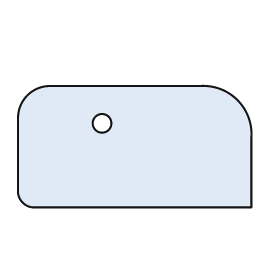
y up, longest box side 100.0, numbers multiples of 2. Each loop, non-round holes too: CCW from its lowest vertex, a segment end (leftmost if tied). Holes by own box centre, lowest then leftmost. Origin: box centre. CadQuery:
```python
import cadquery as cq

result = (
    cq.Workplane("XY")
    .moveTo(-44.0, -26.0)
    .lineTo(50.0, -26.0)
    .lineTo(50.0, 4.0)
    .threePointArc((44.0, 20.0), (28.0, 26.0))
    .lineTo(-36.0, 26.0)
    .threePointArc((-46.0, 22.0), (-50.0, 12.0))
    .lineTo(-50.0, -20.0)
    .threePointArc((-48.0, -24.0), (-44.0, -26.0))
    .close()
    .moveTo(-14.0, 10.0)
    .circle(4.0)
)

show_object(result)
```